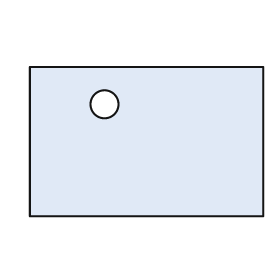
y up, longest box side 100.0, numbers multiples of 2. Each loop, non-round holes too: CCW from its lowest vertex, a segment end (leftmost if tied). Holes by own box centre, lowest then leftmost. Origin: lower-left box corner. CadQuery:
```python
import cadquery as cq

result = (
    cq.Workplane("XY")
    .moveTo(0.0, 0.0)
    .lineTo(100.0, 0.0)
    .lineTo(100.0, 64.0)
    .lineTo(0.0, 64.0)
    .close()
    .moveTo(32.0, 48.0)
    .circle(6.0)
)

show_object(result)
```